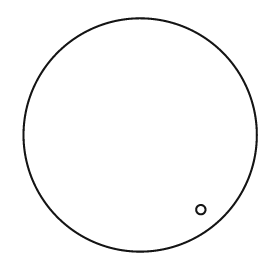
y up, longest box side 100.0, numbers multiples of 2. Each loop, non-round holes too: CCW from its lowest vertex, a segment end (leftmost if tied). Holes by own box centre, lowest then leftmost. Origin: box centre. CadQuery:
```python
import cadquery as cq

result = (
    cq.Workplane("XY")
    .moveTo(0.0, 0.0)
    .circle(50.0)
    .moveTo(26.0, -32.0)
    .circle(2.0)
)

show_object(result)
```